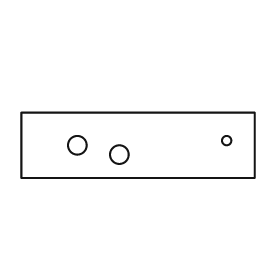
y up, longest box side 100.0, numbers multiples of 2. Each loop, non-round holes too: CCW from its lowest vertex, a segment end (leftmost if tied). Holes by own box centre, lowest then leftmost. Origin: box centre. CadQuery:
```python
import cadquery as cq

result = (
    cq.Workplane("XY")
    .moveTo(-50.0, -14.0)
    .lineTo(50.0, -14.0)
    .lineTo(50.0, 14.0)
    .lineTo(-50.0, 14.0)
    .close()
    .moveTo(-8.0, -4.0)
    .circle(4.0)
    .moveTo(-26.0, 0.0)
    .circle(4.0)
    .moveTo(38.0, 2.0)
    .circle(2.0)
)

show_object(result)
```